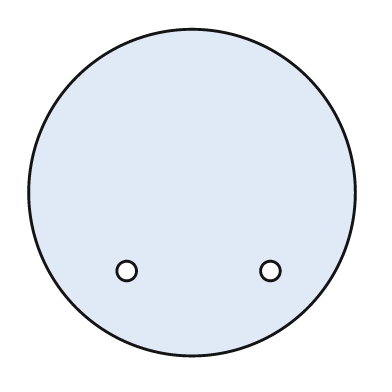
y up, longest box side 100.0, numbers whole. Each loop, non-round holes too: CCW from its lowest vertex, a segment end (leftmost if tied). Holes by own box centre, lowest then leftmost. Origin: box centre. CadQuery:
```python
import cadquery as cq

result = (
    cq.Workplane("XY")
    .moveTo(0.0, 0.0)
    .circle(50.0)
    .moveTo(-20.0, -24.0)
    .circle(3.0)
    .moveTo(24.0, -24.0)
    .circle(3.0)
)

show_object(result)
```